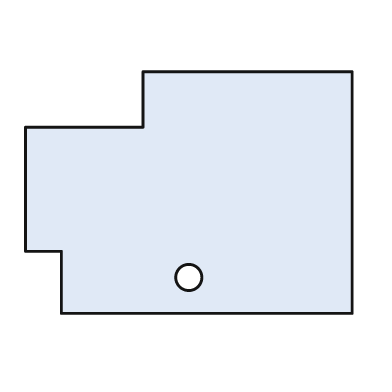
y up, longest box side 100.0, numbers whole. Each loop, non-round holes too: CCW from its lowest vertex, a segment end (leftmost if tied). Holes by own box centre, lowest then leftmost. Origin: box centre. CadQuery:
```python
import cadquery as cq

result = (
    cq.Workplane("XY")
    .moveTo(-39.0, -37.0)
    .lineTo(50.0, -37.0)
    .lineTo(50.0, 37.0)
    .lineTo(-14.0, 37.0)
    .lineTo(-14.0, 20.0)
    .lineTo(-50.0, 20.0)
    .lineTo(-50.0, -18.0)
    .lineTo(-39.0, -18.0)
    .close()
    .moveTo(0.0, -26.0)
    .circle(4.0)
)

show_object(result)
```